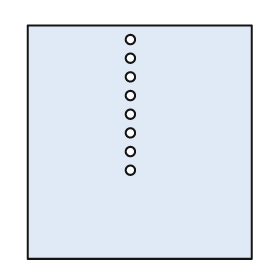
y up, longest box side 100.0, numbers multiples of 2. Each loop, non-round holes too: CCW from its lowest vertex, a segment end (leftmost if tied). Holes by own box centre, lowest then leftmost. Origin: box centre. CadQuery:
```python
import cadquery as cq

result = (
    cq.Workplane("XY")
    .moveTo(-48.0, -50.0)
    .lineTo(48.0, -50.0)
    .lineTo(48.0, 50.0)
    .lineTo(-48.0, 50.0)
    .close()
    .moveTo(-4.0, -12.0)
    .circle(2.0)
    .moveTo(-4.0, -4.0)
    .circle(2.0)
    .moveTo(-4.0, 4.0)
    .circle(2.0)
    .moveTo(-4.0, 12.0)
    .circle(2.0)
    .moveTo(-4.0, 20.0)
    .circle(2.0)
    .moveTo(-4.0, 28.0)
    .circle(2.0)
    .moveTo(-4.0, 36.0)
    .circle(2.0)
    .moveTo(-4.0, 44.0)
    .circle(2.0)
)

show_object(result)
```